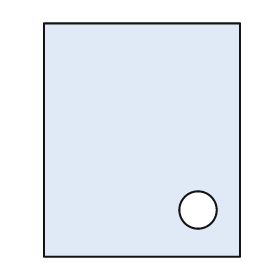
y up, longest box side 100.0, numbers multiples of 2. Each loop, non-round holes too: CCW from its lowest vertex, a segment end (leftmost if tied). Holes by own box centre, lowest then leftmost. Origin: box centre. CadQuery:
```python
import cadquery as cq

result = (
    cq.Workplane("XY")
    .moveTo(-42.0, -50.0)
    .lineTo(42.0, -50.0)
    .lineTo(42.0, 50.0)
    .lineTo(-42.0, 50.0)
    .close()
    .moveTo(24.0, -30.0)
    .circle(8.0)
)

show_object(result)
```